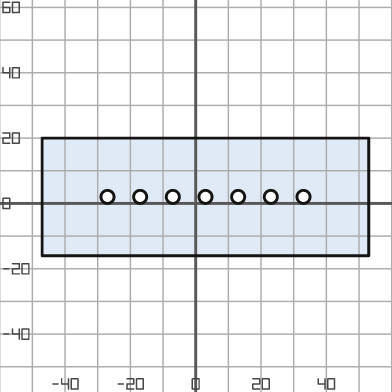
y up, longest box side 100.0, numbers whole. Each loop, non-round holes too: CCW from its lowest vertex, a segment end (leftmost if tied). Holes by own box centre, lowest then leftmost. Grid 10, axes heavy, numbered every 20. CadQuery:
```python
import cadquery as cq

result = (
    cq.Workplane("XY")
    .moveTo(-47.0, -16.0)
    .lineTo(53.0, -16.0)
    .lineTo(53.0, 20.0)
    .lineTo(-47.0, 20.0)
    .close()
    .moveTo(-27.0, 2.0)
    .circle(2.0)
    .moveTo(-17.0, 2.0)
    .circle(2.0)
    .moveTo(-7.0, 2.0)
    .circle(2.0)
    .moveTo(3.0, 2.0)
    .circle(2.0)
    .moveTo(13.0, 2.0)
    .circle(2.0)
    .moveTo(23.0, 2.0)
    .circle(2.0)
    .moveTo(33.0, 2.0)
    .circle(2.0)
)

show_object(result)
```